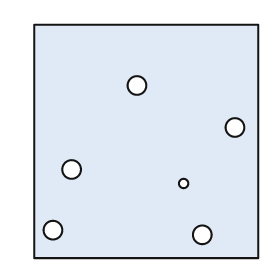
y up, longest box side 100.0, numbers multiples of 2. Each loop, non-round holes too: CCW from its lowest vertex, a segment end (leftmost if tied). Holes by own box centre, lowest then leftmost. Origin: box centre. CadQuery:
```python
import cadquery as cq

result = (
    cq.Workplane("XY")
    .moveTo(-48.0, -50.0)
    .lineTo(48.0, -50.0)
    .lineTo(48.0, 50.0)
    .lineTo(-48.0, 50.0)
    .close()
    .moveTo(24.0, -40.0)
    .circle(4.0)
    .moveTo(-40.0, -38.0)
    .circle(4.0)
    .moveTo(16.0, -18.0)
    .circle(2.0)
    .moveTo(-32.0, -12.0)
    .circle(4.0)
    .moveTo(38.0, 6.0)
    .circle(4.0)
    .moveTo(-4.0, 24.0)
    .circle(4.0)
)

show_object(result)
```